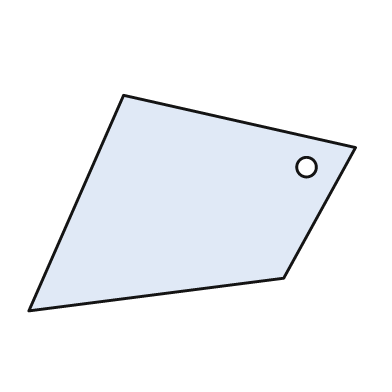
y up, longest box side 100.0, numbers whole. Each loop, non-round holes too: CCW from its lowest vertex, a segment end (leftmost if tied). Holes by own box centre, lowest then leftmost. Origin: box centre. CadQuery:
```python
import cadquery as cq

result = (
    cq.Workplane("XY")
    .moveTo(-50.0, -33.0)
    .lineTo(28.0, -23.0)
    .lineTo(50.0, 17.0)
    .lineTo(-21.0, 33.0)
    .close()
    .moveTo(35.0, 11.0)
    .circle(3.0)
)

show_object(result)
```